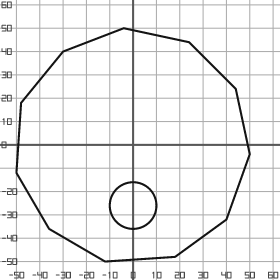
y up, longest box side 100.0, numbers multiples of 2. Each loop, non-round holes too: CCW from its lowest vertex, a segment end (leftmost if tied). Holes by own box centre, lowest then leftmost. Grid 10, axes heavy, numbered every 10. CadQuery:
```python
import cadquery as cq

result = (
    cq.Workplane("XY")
    .moveTo(-12.0, -50.0)
    .lineTo(18.0, -48.0)
    .lineTo(40.0, -32.0)
    .lineTo(50.0, -4.0)
    .lineTo(44.0, 24.0)
    .lineTo(24.0, 44.0)
    .lineTo(-4.0, 50.0)
    .lineTo(-30.0, 40.0)
    .lineTo(-48.0, 18.0)
    .lineTo(-50.0, -12.0)
    .lineTo(-36.0, -36.0)
    .close()
    .moveTo(0.0, -26.0)
    .circle(10.0)
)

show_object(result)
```